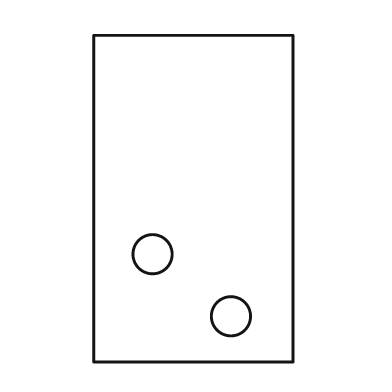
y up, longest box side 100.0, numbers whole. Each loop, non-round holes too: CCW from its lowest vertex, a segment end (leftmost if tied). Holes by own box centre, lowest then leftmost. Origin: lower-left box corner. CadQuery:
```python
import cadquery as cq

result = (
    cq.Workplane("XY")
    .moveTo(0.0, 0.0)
    .lineTo(61.0, 0.0)
    .lineTo(61.0, 100.0)
    .lineTo(0.0, 100.0)
    .close()
    .moveTo(42.0, 14.0)
    .circle(6.0)
    .moveTo(18.0, 33.0)
    .circle(6.0)
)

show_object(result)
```